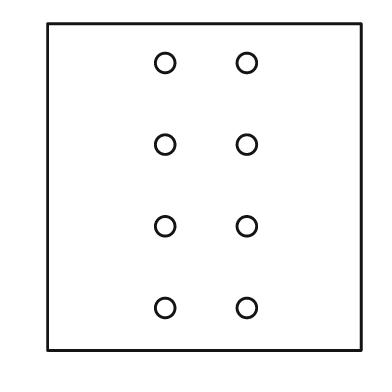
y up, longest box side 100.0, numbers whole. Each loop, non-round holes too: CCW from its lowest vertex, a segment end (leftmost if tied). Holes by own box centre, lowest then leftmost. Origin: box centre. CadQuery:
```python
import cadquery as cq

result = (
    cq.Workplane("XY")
    .moveTo(-48.0, -50.0)
    .lineTo(48.0, -50.0)
    .lineTo(48.0, 50.0)
    .lineTo(-48.0, 50.0)
    .close()
    .moveTo(-12.0, -37.0)
    .circle(3.0)
    .moveTo(13.0, -37.0)
    .circle(3.0)
    .moveTo(-12.0, -12.0)
    .circle(3.0)
    .moveTo(13.0, -12.0)
    .circle(3.0)
    .moveTo(-12.0, 13.0)
    .circle(3.0)
    .moveTo(13.0, 13.0)
    .circle(3.0)
    .moveTo(-12.0, 38.0)
    .circle(3.0)
    .moveTo(13.0, 38.0)
    .circle(3.0)
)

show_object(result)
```